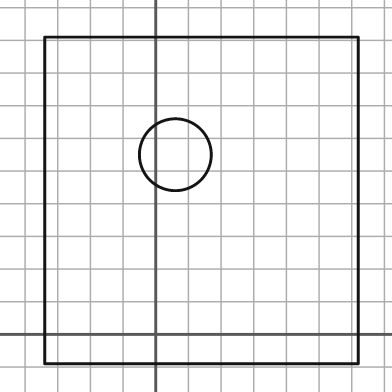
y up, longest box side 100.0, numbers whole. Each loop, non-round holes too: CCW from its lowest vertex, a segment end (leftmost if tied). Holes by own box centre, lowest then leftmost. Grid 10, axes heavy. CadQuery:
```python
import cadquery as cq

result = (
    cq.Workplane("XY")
    .moveTo(-34.0, -9.0)
    .lineTo(62.0, -9.0)
    .lineTo(62.0, 91.0)
    .lineTo(-34.0, 91.0)
    .close()
    .moveTo(6.0, 55.0)
    .circle(11.0)
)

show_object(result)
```